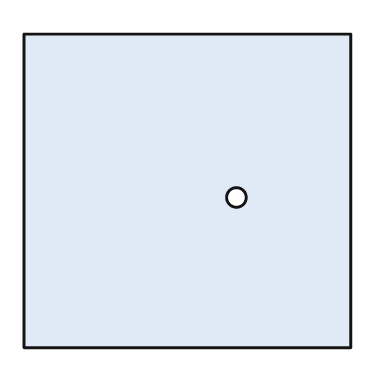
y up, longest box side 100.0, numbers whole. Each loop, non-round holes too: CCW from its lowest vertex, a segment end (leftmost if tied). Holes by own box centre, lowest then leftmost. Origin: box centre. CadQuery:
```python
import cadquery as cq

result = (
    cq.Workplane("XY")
    .moveTo(-50.0, -48.0)
    .lineTo(50.0, -48.0)
    .lineTo(50.0, 48.0)
    .lineTo(-50.0, 48.0)
    .close()
    .moveTo(15.0, -2.0)
    .circle(3.0)
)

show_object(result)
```